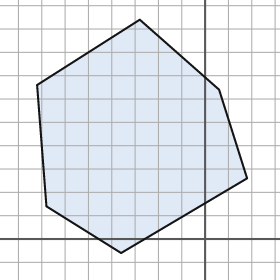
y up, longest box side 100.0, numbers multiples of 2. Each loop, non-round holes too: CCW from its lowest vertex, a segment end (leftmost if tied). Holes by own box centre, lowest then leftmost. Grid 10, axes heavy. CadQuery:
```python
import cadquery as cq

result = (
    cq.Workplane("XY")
    .moveTo(-36.0, -6.0)
    .lineTo(18.0, 26.0)
    .lineTo(6.0, 64.0)
    .lineTo(-28.0, 94.0)
    .lineTo(-72.0, 66.0)
    .lineTo(-68.0, 14.0)
    .close()
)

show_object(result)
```